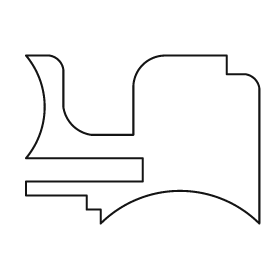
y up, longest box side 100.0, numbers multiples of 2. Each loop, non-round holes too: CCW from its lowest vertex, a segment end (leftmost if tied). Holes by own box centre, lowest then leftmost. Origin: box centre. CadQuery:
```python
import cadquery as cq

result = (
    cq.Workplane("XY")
    .moveTo(-18.0, -36.0)
    .threePointArc((16.0, -22.0), (50.0, -36.0))
    .lineTo(50.0, 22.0)
    .threePointArc((48.0, 26.0), (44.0, 28.0))
    .lineTo(36.0, 28.0)
    .lineTo(36.0, 36.0)
    .lineTo(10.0, 36.0)
    .threePointArc((0.0, 32.0), (-4.0, 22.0))
    .lineTo(-4.0, 2.0)
    .lineTo(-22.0, 2.0)
    .threePointArc((-30.0, 6.0), (-34.0, 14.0))
    .lineTo(-34.0, 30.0)
    .threePointArc((-36.0, 34.0), (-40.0, 36.0))
    .lineTo(-50.0, 36.0)
    .threePointArc((-42.0, 14.0), (-50.0, -8.0))
    .lineTo(0.0, -8.0)
    .lineTo(0.0, -18.0)
    .lineTo(-50.0, -18.0)
    .lineTo(-50.0, -24.0)
    .lineTo(-24.0, -24.0)
    .lineTo(-24.0, -30.0)
    .lineTo(-18.0, -30.0)
    .close()
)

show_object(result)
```